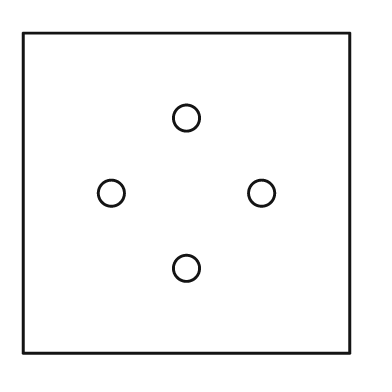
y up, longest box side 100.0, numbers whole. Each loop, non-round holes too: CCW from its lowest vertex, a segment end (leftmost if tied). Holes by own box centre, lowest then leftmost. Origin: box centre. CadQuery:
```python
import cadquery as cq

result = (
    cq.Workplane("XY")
    .moveTo(-50.0, -49.0)
    .lineTo(50.0, -49.0)
    .lineTo(50.0, 49.0)
    .lineTo(-50.0, 49.0)
    .close()
    .moveTo(0.0, -23.0)
    .circle(4.0)
    .moveTo(-23.0, 0.0)
    .circle(4.0)
    .moveTo(23.0, 0.0)
    .circle(4.0)
    .moveTo(0.0, 23.0)
    .circle(4.0)
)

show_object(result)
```